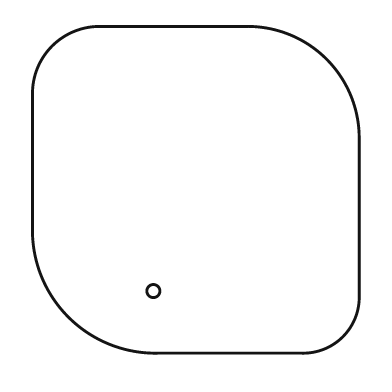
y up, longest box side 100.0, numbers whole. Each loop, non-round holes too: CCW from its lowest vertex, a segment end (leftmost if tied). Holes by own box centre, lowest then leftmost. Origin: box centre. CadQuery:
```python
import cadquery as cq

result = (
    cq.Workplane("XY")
    .moveTo(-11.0, -50.0)
    .lineTo(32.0, -50.0)
    .threePointArc((45.0, -45.0), (50.0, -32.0))
    .lineTo(50.0, 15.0)
    .threePointArc((40.0, 40.0), (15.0, 50.0))
    .lineTo(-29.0, 50.0)
    .threePointArc((-44.0, 44.0), (-50.0, 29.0))
    .lineTo(-50.0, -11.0)
    .threePointArc((-39.0, -39.0), (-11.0, -50.0))
    .close()
    .moveTo(-13.0, -31.0)
    .circle(2.0)
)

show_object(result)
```